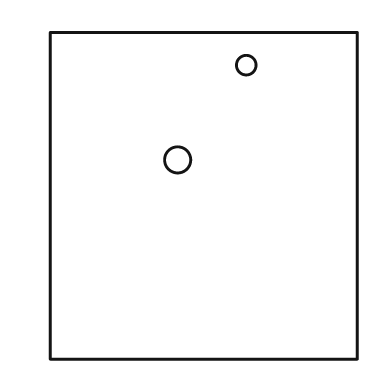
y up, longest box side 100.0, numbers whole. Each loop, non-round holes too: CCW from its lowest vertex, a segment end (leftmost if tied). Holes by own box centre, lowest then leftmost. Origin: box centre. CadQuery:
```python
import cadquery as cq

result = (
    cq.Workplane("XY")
    .moveTo(-47.0, -50.0)
    .lineTo(47.0, -50.0)
    .lineTo(47.0, 50.0)
    .lineTo(-47.0, 50.0)
    .close()
    .moveTo(-8.0, 11.0)
    .circle(4.0)
    .moveTo(13.0, 40.0)
    .circle(3.0)
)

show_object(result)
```